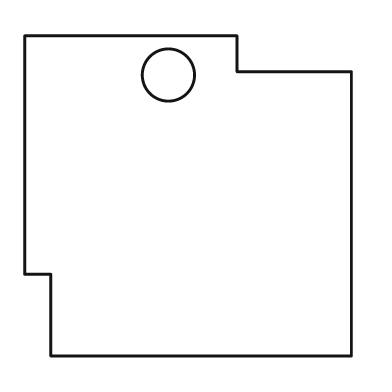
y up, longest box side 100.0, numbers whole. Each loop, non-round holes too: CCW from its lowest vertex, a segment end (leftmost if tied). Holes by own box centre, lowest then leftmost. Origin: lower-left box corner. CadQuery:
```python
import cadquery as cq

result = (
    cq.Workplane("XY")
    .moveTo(8.0, 0.0)
    .lineTo(100.0, 0.0)
    .lineTo(100.0, 87.0)
    .lineTo(65.0, 87.0)
    .lineTo(65.0, 98.0)
    .lineTo(0.0, 98.0)
    .lineTo(0.0, 25.0)
    .lineTo(8.0, 25.0)
    .close()
    .moveTo(44.0, 86.0)
    .circle(8.0)
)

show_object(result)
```